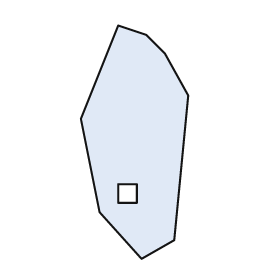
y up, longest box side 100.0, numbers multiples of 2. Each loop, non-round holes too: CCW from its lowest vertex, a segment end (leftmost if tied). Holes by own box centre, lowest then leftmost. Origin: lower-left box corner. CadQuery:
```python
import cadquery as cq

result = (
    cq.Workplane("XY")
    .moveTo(26.0, 0.0)
    .lineTo(40.0, 8.0)
    .lineTo(46.0, 70.0)
    .lineTo(36.0, 88.0)
    .lineTo(28.0, 96.0)
    .lineTo(16.0, 100.0)
    .lineTo(0.0, 60.0)
    .lineTo(8.0, 20.0)
    .close()
    .moveTo(16.0, 24.0)
    .lineTo(24.0, 24.0)
    .lineTo(24.0, 32.0)
    .lineTo(16.0, 32.0)
    .close()
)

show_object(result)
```